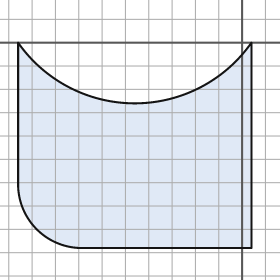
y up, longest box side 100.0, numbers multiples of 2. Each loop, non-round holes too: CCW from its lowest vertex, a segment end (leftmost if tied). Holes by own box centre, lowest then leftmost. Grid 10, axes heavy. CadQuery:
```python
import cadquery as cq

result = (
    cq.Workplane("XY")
    .moveTo(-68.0, -88.0)
    .lineTo(4.0, -88.0)
    .lineTo(4.0, 0.0)
    .threePointArc((-46.0, -26.0), (-96.0, 0.0))
    .lineTo(-96.0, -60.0)
    .threePointArc((-88.0, -80.0), (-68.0, -88.0))
    .close()
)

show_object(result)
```